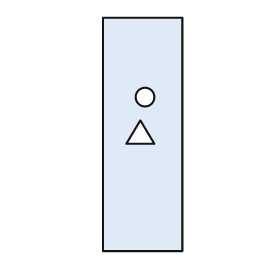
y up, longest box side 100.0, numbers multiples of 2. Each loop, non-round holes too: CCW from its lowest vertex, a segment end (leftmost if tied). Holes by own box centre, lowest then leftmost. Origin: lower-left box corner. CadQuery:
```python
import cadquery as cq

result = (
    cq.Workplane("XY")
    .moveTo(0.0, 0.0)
    .lineTo(34.0, 0.0)
    .lineTo(34.0, 100.0)
    .lineTo(0.0, 100.0)
    .close()
    .moveTo(10.0, 46.0)
    .lineTo(22.0, 46.0)
    .lineTo(16.0, 56.0)
    .close()
    .moveTo(18.0, 66.0)
    .circle(4.0)
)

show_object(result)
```